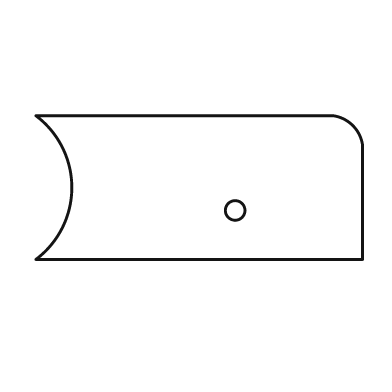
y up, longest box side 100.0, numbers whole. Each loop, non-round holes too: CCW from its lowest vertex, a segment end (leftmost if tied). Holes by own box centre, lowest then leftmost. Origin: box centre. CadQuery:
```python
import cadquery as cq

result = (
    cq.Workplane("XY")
    .moveTo(-50.0, -22.0)
    .lineTo(50.0, -22.0)
    .lineTo(50.0, 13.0)
    .threePointArc((47.0, 19.0), (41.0, 22.0))
    .lineTo(-50.0, 22.0)
    .threePointArc((-39.0, 0.0), (-50.0, -22.0))
    .close()
    .moveTo(11.0, -7.0)
    .circle(3.0)
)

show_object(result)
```